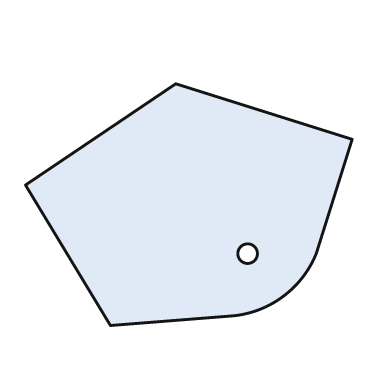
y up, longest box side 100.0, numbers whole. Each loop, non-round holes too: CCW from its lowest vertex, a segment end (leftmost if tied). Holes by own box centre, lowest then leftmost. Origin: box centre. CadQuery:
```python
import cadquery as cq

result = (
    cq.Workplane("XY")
    .moveTo(-24.0, -37.0)
    .lineTo(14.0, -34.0)
    .threePointArc((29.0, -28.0), (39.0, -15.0))
    .lineTo(50.0, 20.0)
    .lineTo(-4.0, 37.0)
    .lineTo(-50.0, 6.0)
    .close()
    .moveTo(18.0, -15.0)
    .circle(3.0)
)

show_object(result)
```